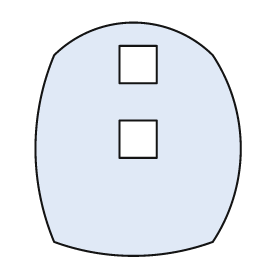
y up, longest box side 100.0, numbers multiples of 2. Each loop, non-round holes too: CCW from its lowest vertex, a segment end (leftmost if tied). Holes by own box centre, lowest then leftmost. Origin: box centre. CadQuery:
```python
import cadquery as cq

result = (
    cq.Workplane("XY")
    .moveTo(-36.0, -44.0)
    .threePointArc((-2.0, -50.0), (32.0, -44.0))
    .threePointArc((44.0, -4.0), (32.0, 36.0))
    .threePointArc((-2.0, 50.0), (-36.0, 36.0))
    .threePointArc((-44.0, -4.0), (-36.0, -44.0))
    .close()
    .moveTo(-8.0, -8.0)
    .lineTo(8.0, -8.0)
    .lineTo(8.0, 8.0)
    .lineTo(-8.0, 8.0)
    .close()
    .moveTo(-8.0, 24.0)
    .lineTo(8.0, 24.0)
    .lineTo(8.0, 40.0)
    .lineTo(-8.0, 40.0)
    .close()
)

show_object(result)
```